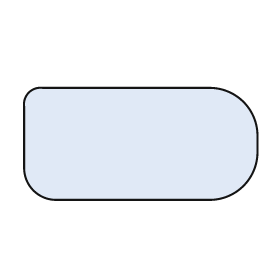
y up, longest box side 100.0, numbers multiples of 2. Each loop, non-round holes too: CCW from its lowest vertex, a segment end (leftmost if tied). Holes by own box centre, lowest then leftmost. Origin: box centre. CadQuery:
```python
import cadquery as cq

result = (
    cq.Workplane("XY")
    .moveTo(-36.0, -24.0)
    .lineTo(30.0, -24.0)
    .threePointArc((44.0, -18.0), (50.0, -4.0))
    .lineTo(50.0, 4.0)
    .threePointArc((44.0, 18.0), (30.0, 24.0))
    .lineTo(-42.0, 24.0)
    .threePointArc((-48.0, 22.0), (-50.0, 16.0))
    .lineTo(-50.0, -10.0)
    .threePointArc((-46.0, -20.0), (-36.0, -24.0))
    .close()
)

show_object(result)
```